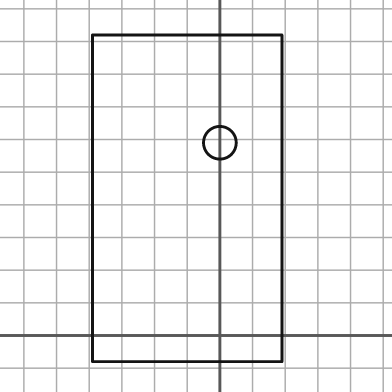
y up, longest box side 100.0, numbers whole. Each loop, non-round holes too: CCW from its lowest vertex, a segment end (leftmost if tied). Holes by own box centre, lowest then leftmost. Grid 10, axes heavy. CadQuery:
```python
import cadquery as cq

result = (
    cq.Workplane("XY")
    .moveTo(-39.0, -8.0)
    .lineTo(19.0, -8.0)
    .lineTo(19.0, 92.0)
    .lineTo(-39.0, 92.0)
    .close()
    .moveTo(0.0, 59.0)
    .circle(5.0)
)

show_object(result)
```